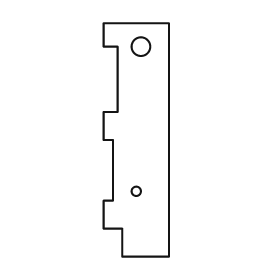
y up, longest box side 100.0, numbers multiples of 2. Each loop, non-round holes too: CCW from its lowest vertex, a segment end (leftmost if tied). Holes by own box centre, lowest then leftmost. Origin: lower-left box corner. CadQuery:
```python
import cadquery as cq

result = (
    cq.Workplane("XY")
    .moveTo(8.0, 0.0)
    .lineTo(28.0, 0.0)
    .lineTo(28.0, 100.0)
    .lineTo(0.0, 100.0)
    .lineTo(0.0, 90.0)
    .lineTo(6.0, 90.0)
    .lineTo(6.0, 62.0)
    .lineTo(0.0, 62.0)
    .lineTo(0.0, 50.0)
    .lineTo(4.0, 50.0)
    .lineTo(4.0, 24.0)
    .lineTo(0.0, 24.0)
    .lineTo(0.0, 12.0)
    .lineTo(8.0, 12.0)
    .close()
    .moveTo(14.0, 28.0)
    .circle(2.0)
    .moveTo(16.0, 90.0)
    .circle(4.0)
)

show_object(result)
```